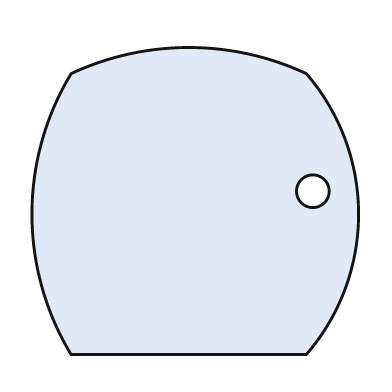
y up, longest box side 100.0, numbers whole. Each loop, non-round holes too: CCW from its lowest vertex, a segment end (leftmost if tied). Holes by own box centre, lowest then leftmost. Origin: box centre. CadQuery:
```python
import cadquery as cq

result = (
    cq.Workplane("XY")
    .moveTo(-38.0, -47.0)
    .lineTo(34.0, -47.0)
    .threePointArc((50.0, -4.0), (34.0, 39.0))
    .threePointArc((-2.0, 47.0), (-38.0, 39.0))
    .threePointArc((-50.0, -4.0), (-38.0, -47.0))
    .close()
    .moveTo(36.0, 3.0)
    .circle(5.0)
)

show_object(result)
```